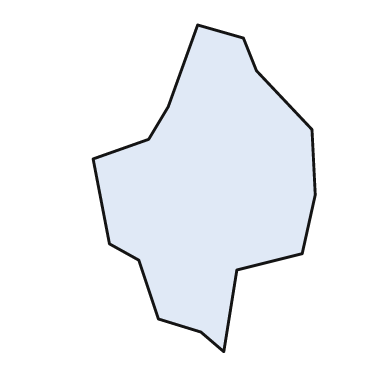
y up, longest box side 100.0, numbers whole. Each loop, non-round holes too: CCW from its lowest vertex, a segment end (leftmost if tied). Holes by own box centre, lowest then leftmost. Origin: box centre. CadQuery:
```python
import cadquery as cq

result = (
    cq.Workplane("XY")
    .moveTo(6.0, -50.0)
    .lineTo(10.0, -25.0)
    .lineTo(30.0, -20.0)
    .lineTo(34.0, -2.0)
    .lineTo(33.0, 18.0)
    .lineTo(16.0, 36.0)
    .lineTo(12.0, 46.0)
    .lineTo(-2.0, 50.0)
    .lineTo(-11.0, 25.0)
    .lineTo(-17.0, 15.0)
    .lineTo(-34.0, 9.0)
    .lineTo(-29.0, -17.0)
    .lineTo(-20.0, -22.0)
    .lineTo(-14.0, -40.0)
    .lineTo(-1.0, -44.0)
    .close()
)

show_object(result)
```